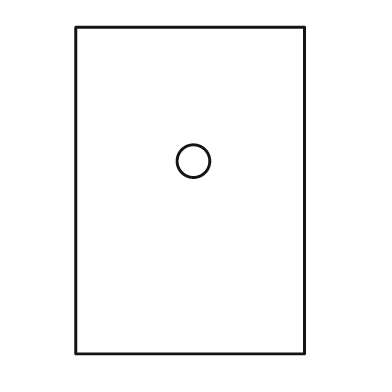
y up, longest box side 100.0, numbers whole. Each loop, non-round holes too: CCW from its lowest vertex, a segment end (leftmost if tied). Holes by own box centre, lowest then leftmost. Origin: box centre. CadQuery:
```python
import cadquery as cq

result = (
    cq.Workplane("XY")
    .moveTo(-35.0, -50.0)
    .lineTo(35.0, -50.0)
    .lineTo(35.0, 50.0)
    .lineTo(-35.0, 50.0)
    .close()
    .moveTo(1.0, 9.0)
    .circle(5.0)
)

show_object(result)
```